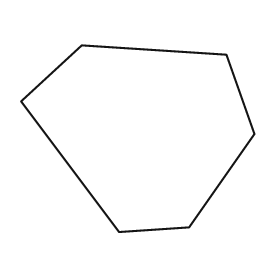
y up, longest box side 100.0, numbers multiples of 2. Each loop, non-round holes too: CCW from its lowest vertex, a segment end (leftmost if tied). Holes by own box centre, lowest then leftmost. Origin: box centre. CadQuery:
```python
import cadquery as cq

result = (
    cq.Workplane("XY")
    .moveTo(-8.0, -40.0)
    .lineTo(22.0, -38.0)
    .lineTo(50.0, 2.0)
    .lineTo(38.0, 36.0)
    .lineTo(-24.0, 40.0)
    .lineTo(-50.0, 16.0)
    .close()
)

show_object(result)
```